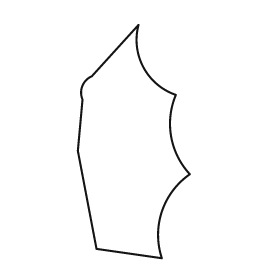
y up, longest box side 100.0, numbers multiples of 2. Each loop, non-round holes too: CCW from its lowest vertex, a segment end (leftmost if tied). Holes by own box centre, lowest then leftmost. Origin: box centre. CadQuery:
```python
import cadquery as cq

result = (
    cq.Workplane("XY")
    .moveTo(12.0, -50.0)
    .threePointArc((12.0, -30.0), (24.0, -14.0))
    .threePointArc((16.0, 2.0), (18.0, 20.0))
    .threePointArc((4.0, 32.0), (2.0, 50.0))
    .lineTo(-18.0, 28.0)
    .threePointArc((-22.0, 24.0), (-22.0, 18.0))
    .lineTo(-24.0, -4.0)
    .lineTo(-16.0, -46.0)
    .close()
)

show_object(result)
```